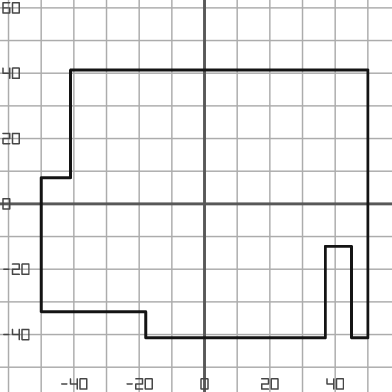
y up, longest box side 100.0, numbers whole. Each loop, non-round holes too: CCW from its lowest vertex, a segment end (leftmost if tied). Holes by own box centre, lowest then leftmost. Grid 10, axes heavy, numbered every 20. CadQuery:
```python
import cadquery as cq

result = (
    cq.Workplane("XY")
    .moveTo(-18.0, -41.0)
    .lineTo(37.0, -41.0)
    .lineTo(37.0, -13.0)
    .lineTo(45.0, -13.0)
    .lineTo(45.0, -41.0)
    .lineTo(50.0, -41.0)
    .lineTo(50.0, 41.0)
    .lineTo(-41.0, 41.0)
    .lineTo(-41.0, 8.0)
    .lineTo(-50.0, 8.0)
    .lineTo(-50.0, -33.0)
    .lineTo(-18.0, -33.0)
    .close()
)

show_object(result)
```